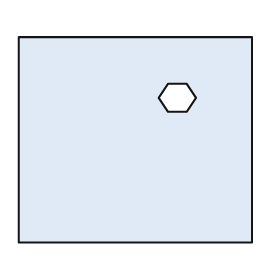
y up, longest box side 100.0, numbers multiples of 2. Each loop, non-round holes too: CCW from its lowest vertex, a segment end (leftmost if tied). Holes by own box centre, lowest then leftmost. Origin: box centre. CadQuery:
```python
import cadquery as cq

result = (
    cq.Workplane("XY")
    .moveTo(-50.0, -44.0)
    .lineTo(50.0, -44.0)
    .lineTo(50.0, 44.0)
    .lineTo(-50.0, 44.0)
    .close()
    .moveTo(14.0, 12.0)
    .lineTo(22.0, 12.0)
    .lineTo(26.0, 18.0)
    .lineTo(22.0, 24.0)
    .lineTo(14.0, 24.0)
    .lineTo(10.0, 18.0)
    .close()
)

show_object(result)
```